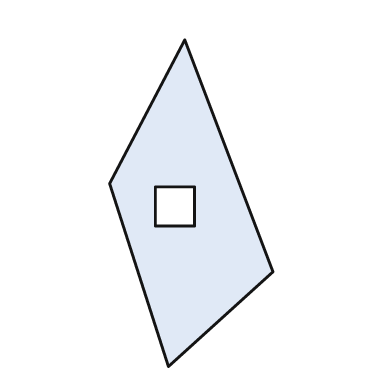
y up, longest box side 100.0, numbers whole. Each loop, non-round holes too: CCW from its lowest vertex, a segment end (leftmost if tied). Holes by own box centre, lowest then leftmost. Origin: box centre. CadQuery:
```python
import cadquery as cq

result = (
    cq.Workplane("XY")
    .moveTo(-7.0, -50.0)
    .lineTo(25.0, -21.0)
    .lineTo(-2.0, 50.0)
    .lineTo(-25.0, 6.0)
    .close()
    .moveTo(-11.0, -7.0)
    .lineTo(1.0, -7.0)
    .lineTo(1.0, 5.0)
    .lineTo(-11.0, 5.0)
    .close()
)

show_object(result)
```